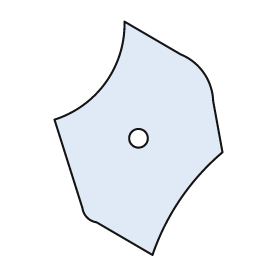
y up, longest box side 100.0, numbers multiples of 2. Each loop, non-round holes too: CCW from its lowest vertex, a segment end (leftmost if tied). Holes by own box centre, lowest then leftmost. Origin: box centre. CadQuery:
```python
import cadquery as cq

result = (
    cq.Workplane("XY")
    .moveTo(6.0, -50.0)
    .threePointArc((18.0, -26.0), (36.0, -6.0))
    .lineTo(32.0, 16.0)
    .threePointArc((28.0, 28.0), (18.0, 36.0))
    .lineTo(-6.0, 50.0)
    .threePointArc((-14.0, 24.0), (-36.0, 8.0))
    .lineTo(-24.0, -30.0)
    .threePointArc((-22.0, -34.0), (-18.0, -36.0))
    .close()
    .moveTo(0.0, 0.0)
    .circle(4.0)
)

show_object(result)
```